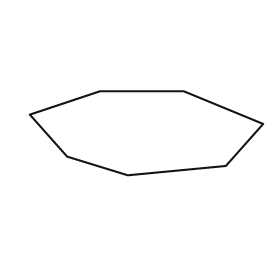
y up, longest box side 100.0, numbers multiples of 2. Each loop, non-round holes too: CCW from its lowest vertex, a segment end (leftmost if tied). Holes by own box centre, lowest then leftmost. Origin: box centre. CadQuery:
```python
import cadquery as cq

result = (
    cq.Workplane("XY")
    .moveTo(-8.0, -18.0)
    .lineTo(34.0, -14.0)
    .lineTo(50.0, 4.0)
    .lineTo(16.0, 18.0)
    .lineTo(-20.0, 18.0)
    .lineTo(-50.0, 8.0)
    .lineTo(-34.0, -10.0)
    .close()
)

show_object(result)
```